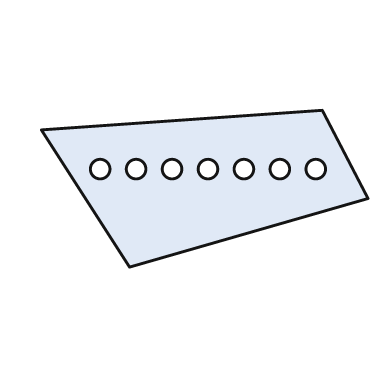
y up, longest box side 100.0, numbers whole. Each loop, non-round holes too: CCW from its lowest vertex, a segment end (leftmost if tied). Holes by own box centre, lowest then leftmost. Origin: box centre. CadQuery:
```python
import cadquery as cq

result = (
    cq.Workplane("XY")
    .moveTo(-23.0, -24.0)
    .lineTo(50.0, -3.0)
    .lineTo(36.0, 24.0)
    .lineTo(-50.0, 18.0)
    .close()
    .moveTo(-32.0, 6.0)
    .circle(3.0)
    .moveTo(-21.0, 6.0)
    .circle(3.0)
    .moveTo(-10.0, 6.0)
    .circle(3.0)
    .moveTo(1.0, 6.0)
    .circle(3.0)
    .moveTo(12.0, 6.0)
    .circle(3.0)
    .moveTo(23.0, 6.0)
    .circle(3.0)
    .moveTo(34.0, 6.0)
    .circle(3.0)
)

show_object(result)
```